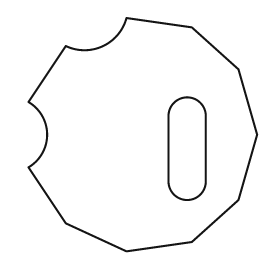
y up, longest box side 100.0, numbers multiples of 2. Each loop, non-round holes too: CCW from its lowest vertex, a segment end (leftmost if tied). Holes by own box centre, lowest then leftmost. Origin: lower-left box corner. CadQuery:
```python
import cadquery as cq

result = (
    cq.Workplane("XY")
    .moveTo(42.0, 0.0)
    .lineTo(70.0, 4.0)
    .lineTo(90.0, 22.0)
    .lineTo(98.0, 50.0)
    .lineTo(90.0, 78.0)
    .lineTo(70.0, 96.0)
    .lineTo(42.0, 100.0)
    .threePointArc((32.0, 88.0), (16.0, 88.0))
    .lineTo(0.0, 64.0)
    .threePointArc((8.0, 50.0), (0.0, 36.0))
    .lineTo(16.0, 12.0)
    .close()
    .moveTo(60.0, 30.0)
    .threePointArc((68.0, 22.0), (76.0, 30.0))
    .lineTo(76.0, 58.0)
    .threePointArc((68.0, 66.0), (60.0, 58.0))
    .close()
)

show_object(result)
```